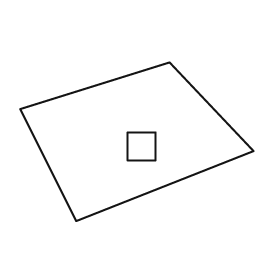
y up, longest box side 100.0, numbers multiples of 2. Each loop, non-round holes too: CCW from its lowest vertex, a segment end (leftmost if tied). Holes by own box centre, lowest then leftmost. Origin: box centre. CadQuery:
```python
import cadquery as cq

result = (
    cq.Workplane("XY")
    .moveTo(-26.0, -34.0)
    .lineTo(50.0, -4.0)
    .lineTo(14.0, 34.0)
    .lineTo(-50.0, 14.0)
    .close()
    .moveTo(-4.0, -8.0)
    .lineTo(8.0, -8.0)
    .lineTo(8.0, 4.0)
    .lineTo(-4.0, 4.0)
    .close()
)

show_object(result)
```